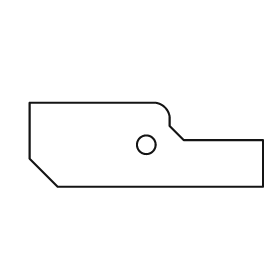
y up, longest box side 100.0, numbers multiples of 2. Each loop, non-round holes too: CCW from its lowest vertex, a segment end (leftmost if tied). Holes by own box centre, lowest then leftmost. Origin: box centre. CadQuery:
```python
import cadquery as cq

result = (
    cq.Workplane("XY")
    .moveTo(-38.0, -18.0)
    .lineTo(50.0, -18.0)
    .lineTo(50.0, 2.0)
    .lineTo(16.0, 2.0)
    .lineTo(10.0, 8.0)
    .lineTo(10.0, 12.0)
    .threePointArc((8.0, 16.0), (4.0, 18.0))
    .lineTo(-50.0, 18.0)
    .lineTo(-50.0, -6.0)
    .close()
    .moveTo(0.0, 0.0)
    .circle(4.0)
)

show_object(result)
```